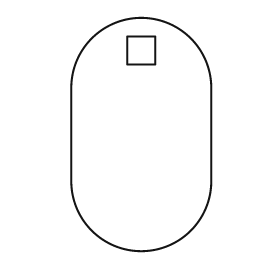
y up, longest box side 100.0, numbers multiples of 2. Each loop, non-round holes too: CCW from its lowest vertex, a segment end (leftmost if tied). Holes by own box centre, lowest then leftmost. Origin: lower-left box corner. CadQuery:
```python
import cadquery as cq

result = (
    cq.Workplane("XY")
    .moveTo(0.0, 30.0)
    .threePointArc((30.0, 0.0), (60.0, 30.0))
    .lineTo(60.0, 70.0)
    .threePointArc((30.0, 100.0), (0.0, 70.0))
    .close()
    .moveTo(24.0, 80.0)
    .lineTo(36.0, 80.0)
    .lineTo(36.0, 92.0)
    .lineTo(24.0, 92.0)
    .close()
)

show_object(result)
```